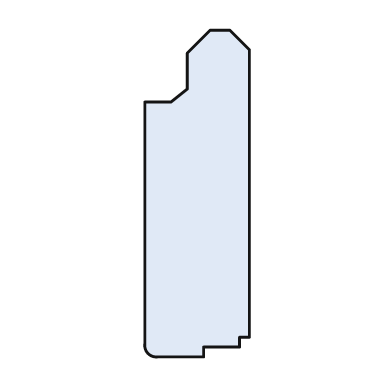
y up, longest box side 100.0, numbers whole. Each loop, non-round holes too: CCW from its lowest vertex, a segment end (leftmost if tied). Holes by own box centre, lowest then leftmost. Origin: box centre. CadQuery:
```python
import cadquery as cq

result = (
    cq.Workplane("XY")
    .moveTo(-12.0, -50.0)
    .lineTo(2.0, -50.0)
    .lineTo(2.0, -47.0)
    .lineTo(13.0, -47.0)
    .lineTo(13.0, -44.0)
    .lineTo(16.0, -44.0)
    .lineTo(16.0, 44.0)
    .lineTo(10.0, 50.0)
    .lineTo(4.0, 50.0)
    .lineTo(-3.0, 43.0)
    .lineTo(-3.0, 32.0)
    .lineTo(-8.0, 28.0)
    .lineTo(-16.0, 28.0)
    .lineTo(-16.0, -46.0)
    .threePointArc((-15.0, -49.0), (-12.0, -50.0))
    .close()
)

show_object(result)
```